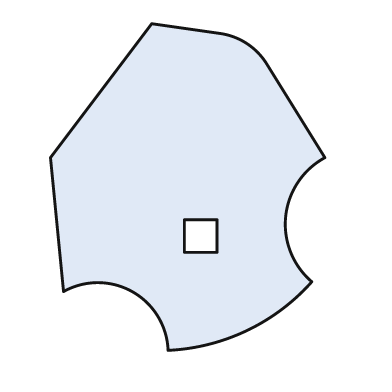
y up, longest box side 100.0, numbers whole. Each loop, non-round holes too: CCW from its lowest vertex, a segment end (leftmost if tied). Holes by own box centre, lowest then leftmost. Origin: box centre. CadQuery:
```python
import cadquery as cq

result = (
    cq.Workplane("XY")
    .moveTo(-6.0, -50.0)
    .threePointArc((18.0, -44.0), (38.0, -29.0))
    .threePointArc((30.0, -9.0), (42.0, 9.0))
    .lineTo(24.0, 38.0)
    .threePointArc((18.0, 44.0), (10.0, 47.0))
    .lineTo(-11.0, 50.0)
    .lineTo(-42.0, 9.0)
    .lineTo(-38.0, -32.0)
    .threePointArc((-17.0, -32.0), (-6.0, -50.0))
    .close()
    .moveTo(-1.0, -20.0)
    .lineTo(9.0, -20.0)
    .lineTo(9.0, -10.0)
    .lineTo(-1.0, -10.0)
    .close()
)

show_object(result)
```